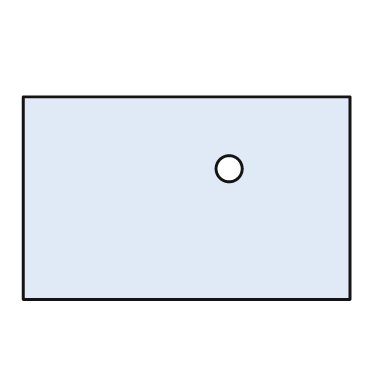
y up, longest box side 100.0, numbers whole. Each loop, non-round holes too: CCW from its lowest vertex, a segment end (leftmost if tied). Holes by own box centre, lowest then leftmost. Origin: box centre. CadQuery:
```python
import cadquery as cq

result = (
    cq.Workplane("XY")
    .moveTo(-50.0, -31.0)
    .lineTo(50.0, -31.0)
    .lineTo(50.0, 31.0)
    .lineTo(-50.0, 31.0)
    .close()
    .moveTo(13.0, 9.0)
    .circle(4.0)
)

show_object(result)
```